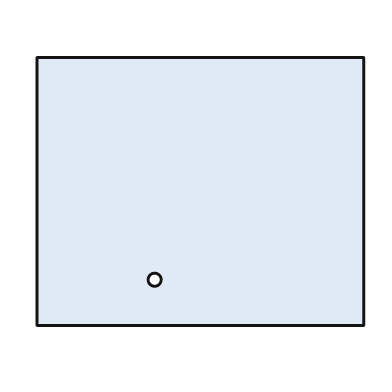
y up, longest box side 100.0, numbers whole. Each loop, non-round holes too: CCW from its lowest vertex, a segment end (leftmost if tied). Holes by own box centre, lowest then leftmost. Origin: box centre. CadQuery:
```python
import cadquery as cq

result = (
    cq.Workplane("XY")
    .moveTo(-50.0, -41.0)
    .lineTo(50.0, -41.0)
    .lineTo(50.0, 41.0)
    .lineTo(-50.0, 41.0)
    .close()
    .moveTo(-14.0, -27.0)
    .circle(2.0)
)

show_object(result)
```